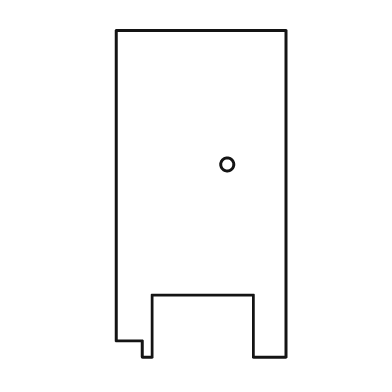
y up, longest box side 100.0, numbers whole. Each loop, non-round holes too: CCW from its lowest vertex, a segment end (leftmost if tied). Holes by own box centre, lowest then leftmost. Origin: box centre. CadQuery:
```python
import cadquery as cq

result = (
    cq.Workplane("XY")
    .moveTo(-18.0, -50.0)
    .lineTo(-15.0, -50.0)
    .lineTo(-15.0, -31.0)
    .lineTo(16.0, -31.0)
    .lineTo(16.0, -50.0)
    .lineTo(26.0, -50.0)
    .lineTo(26.0, 50.0)
    .lineTo(-26.0, 50.0)
    .lineTo(-26.0, -45.0)
    .lineTo(-18.0, -45.0)
    .close()
    .moveTo(8.0, 9.0)
    .circle(2.0)
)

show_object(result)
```